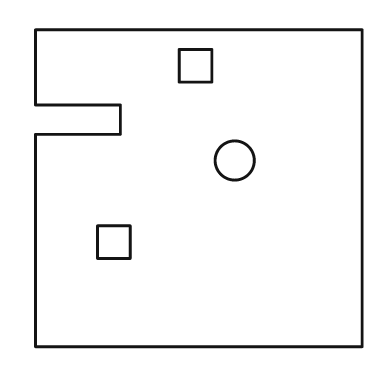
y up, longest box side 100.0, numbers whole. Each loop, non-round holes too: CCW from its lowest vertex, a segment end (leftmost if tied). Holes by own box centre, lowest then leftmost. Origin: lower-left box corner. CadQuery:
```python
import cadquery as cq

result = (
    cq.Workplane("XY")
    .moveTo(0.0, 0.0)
    .lineTo(100.0, 0.0)
    .lineTo(100.0, 97.0)
    .lineTo(0.0, 97.0)
    .lineTo(0.0, 74.0)
    .lineTo(26.0, 74.0)
    .lineTo(26.0, 65.0)
    .lineTo(0.0, 65.0)
    .close()
    .moveTo(19.0, 27.0)
    .lineTo(29.0, 27.0)
    .lineTo(29.0, 37.0)
    .lineTo(19.0, 37.0)
    .close()
    .moveTo(61.0, 57.0)
    .circle(6.0)
    .moveTo(44.0, 81.0)
    .lineTo(54.0, 81.0)
    .lineTo(54.0, 91.0)
    .lineTo(44.0, 91.0)
    .close()
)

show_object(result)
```